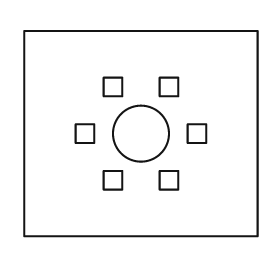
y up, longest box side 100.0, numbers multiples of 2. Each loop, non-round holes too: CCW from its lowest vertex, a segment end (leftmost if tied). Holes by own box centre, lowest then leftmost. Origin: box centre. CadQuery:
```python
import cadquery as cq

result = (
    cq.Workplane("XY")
    .moveTo(-50.0, -44.0)
    .lineTo(50.0, -44.0)
    .lineTo(50.0, 44.0)
    .lineTo(-50.0, 44.0)
    .close()
    .moveTo(-16.0, -24.0)
    .lineTo(-8.0, -24.0)
    .lineTo(-8.0, -16.0)
    .lineTo(-16.0, -16.0)
    .close()
    .moveTo(8.0, -24.0)
    .lineTo(16.0, -24.0)
    .lineTo(16.0, -16.0)
    .lineTo(8.0, -16.0)
    .close()
    .moveTo(-28.0, -4.0)
    .lineTo(-20.0, -4.0)
    .lineTo(-20.0, 4.0)
    .lineTo(-28.0, 4.0)
    .close()
    .moveTo(0.0, 0.0)
    .circle(12.0)
    .moveTo(20.0, -4.0)
    .lineTo(28.0, -4.0)
    .lineTo(28.0, 4.0)
    .lineTo(20.0, 4.0)
    .close()
    .moveTo(-16.0, 16.0)
    .lineTo(-8.0, 16.0)
    .lineTo(-8.0, 24.0)
    .lineTo(-16.0, 24.0)
    .close()
    .moveTo(8.0, 16.0)
    .lineTo(16.0, 16.0)
    .lineTo(16.0, 24.0)
    .lineTo(8.0, 24.0)
    .close()
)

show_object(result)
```